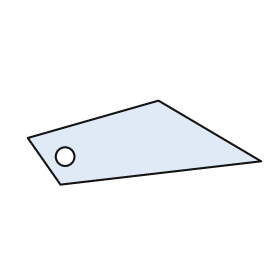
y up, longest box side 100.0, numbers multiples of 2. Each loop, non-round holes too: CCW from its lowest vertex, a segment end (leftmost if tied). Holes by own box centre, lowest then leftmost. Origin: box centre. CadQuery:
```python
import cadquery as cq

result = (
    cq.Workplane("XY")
    .moveTo(-36.0, -18.0)
    .lineTo(50.0, -8.0)
    .lineTo(6.0, 18.0)
    .lineTo(-50.0, 2.0)
    .close()
    .moveTo(-34.0, -6.0)
    .circle(4.0)
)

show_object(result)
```